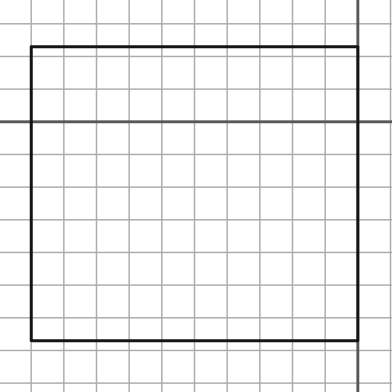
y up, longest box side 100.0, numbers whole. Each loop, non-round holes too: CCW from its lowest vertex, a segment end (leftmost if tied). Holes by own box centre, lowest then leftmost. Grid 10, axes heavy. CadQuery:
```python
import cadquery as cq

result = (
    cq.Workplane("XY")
    .moveTo(-100.0, -67.0)
    .lineTo(0.0, -67.0)
    .lineTo(0.0, 23.0)
    .lineTo(-100.0, 23.0)
    .close()
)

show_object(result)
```